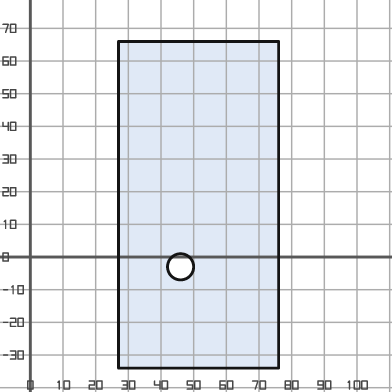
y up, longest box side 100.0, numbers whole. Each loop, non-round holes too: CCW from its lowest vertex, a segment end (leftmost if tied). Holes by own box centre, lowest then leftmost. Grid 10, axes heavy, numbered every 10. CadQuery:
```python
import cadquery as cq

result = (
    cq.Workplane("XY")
    .moveTo(27.0, -34.0)
    .lineTo(76.0, -34.0)
    .lineTo(76.0, 66.0)
    .lineTo(27.0, 66.0)
    .close()
    .moveTo(46.0, -3.0)
    .circle(4.0)
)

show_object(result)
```